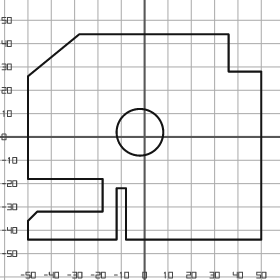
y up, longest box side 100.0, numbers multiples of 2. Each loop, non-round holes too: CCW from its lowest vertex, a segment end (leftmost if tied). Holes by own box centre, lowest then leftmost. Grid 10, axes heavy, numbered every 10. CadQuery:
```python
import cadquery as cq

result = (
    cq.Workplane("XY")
    .moveTo(-50.0, -44.0)
    .lineTo(-12.0, -44.0)
    .lineTo(-12.0, -22.0)
    .lineTo(-8.0, -22.0)
    .lineTo(-8.0, -44.0)
    .lineTo(50.0, -44.0)
    .lineTo(50.0, 28.0)
    .lineTo(36.0, 28.0)
    .lineTo(36.0, 44.0)
    .lineTo(-28.0, 44.0)
    .lineTo(-50.0, 26.0)
    .lineTo(-50.0, -18.0)
    .lineTo(-18.0, -18.0)
    .lineTo(-18.0, -32.0)
    .lineTo(-46.0, -32.0)
    .lineTo(-50.0, -36.0)
    .close()
    .moveTo(-2.0, 2.0)
    .circle(10.0)
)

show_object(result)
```